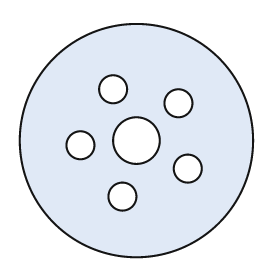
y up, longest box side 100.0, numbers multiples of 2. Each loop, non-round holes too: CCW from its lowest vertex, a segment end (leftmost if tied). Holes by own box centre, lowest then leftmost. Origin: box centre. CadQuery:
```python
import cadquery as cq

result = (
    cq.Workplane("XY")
    .moveTo(0.0, 0.0)
    .circle(50.0)
    .moveTo(-6.0, -24.0)
    .circle(6.0)
    .moveTo(22.0, -12.0)
    .circle(6.0)
    .moveTo(-24.0, -2.0)
    .circle(6.0)
    .moveTo(0.0, 0.0)
    .circle(10.0)
    .moveTo(18.0, 16.0)
    .circle(6.0)
    .moveTo(-10.0, 22.0)
    .circle(6.0)
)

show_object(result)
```